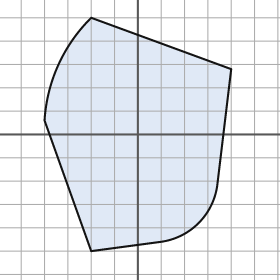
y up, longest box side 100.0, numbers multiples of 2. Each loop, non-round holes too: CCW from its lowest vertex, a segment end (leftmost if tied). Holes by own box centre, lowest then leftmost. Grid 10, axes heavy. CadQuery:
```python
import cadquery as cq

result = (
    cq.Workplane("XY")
    .moveTo(-20.0, -50.0)
    .lineTo(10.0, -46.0)
    .threePointArc((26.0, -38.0), (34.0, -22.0))
    .lineTo(40.0, 28.0)
    .lineTo(-20.0, 50.0)
    .threePointArc((-34.0, 30.0), (-40.0, 6.0))
    .close()
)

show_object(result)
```